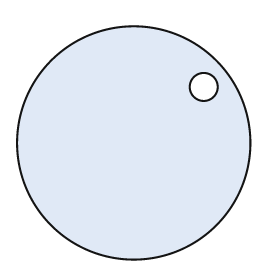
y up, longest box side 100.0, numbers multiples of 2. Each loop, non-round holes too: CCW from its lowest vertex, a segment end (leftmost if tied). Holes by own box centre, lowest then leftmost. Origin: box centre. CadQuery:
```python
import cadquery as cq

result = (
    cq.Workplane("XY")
    .moveTo(0.0, 0.0)
    .circle(50.0)
    .moveTo(30.0, 24.0)
    .circle(6.0)
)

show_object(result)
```